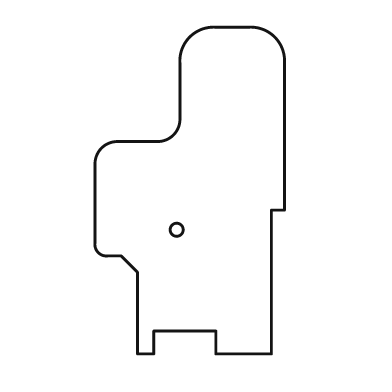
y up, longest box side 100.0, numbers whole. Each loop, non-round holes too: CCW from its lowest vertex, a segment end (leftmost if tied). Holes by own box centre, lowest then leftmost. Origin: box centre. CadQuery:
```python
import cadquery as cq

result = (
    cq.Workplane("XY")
    .moveTo(-16.0, -50.0)
    .lineTo(-11.0, -50.0)
    .lineTo(-11.0, -43.0)
    .lineTo(8.0, -43.0)
    .lineTo(8.0, -50.0)
    .lineTo(25.0, -50.0)
    .lineTo(25.0, -6.0)
    .lineTo(29.0, -6.0)
    .lineTo(29.0, 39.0)
    .threePointArc((26.0, 47.0), (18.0, 50.0))
    .lineTo(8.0, 50.0)
    .threePointArc((0.0, 47.0), (-3.0, 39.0))
    .lineTo(-3.0, 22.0)
    .threePointArc((-5.0, 17.0), (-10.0, 15.0))
    .lineTo(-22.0, 15.0)
    .threePointArc((-27.0, 13.0), (-29.0, 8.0))
    .lineTo(-29.0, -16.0)
    .threePointArc((-28.0, -19.0), (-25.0, -20.0))
    .lineTo(-21.0, -20.0)
    .lineTo(-16.0, -25.0)
    .close()
    .moveTo(-4.0, -12.0)
    .circle(2.0)
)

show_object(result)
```